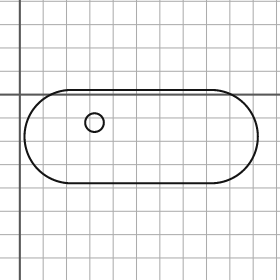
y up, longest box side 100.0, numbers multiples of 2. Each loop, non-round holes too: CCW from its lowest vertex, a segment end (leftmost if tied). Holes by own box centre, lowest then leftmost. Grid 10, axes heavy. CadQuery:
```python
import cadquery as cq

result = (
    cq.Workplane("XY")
    .moveTo(22.0, -38.0)
    .lineTo(82.0, -38.0)
    .threePointArc((102.0, -18.0), (82.0, 2.0))
    .lineTo(22.0, 2.0)
    .threePointArc((2.0, -18.0), (22.0, -38.0))
    .close()
    .moveTo(32.0, -12.0)
    .circle(4.0)
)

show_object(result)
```